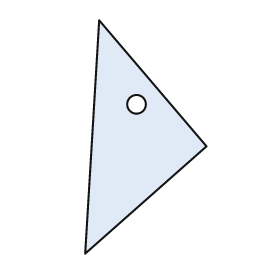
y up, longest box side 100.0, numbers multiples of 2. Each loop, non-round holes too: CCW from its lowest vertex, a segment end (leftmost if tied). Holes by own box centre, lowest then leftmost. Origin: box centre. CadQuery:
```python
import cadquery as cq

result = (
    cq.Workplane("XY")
    .moveTo(-26.0, -50.0)
    .lineTo(26.0, -4.0)
    .lineTo(-20.0, 50.0)
    .close()
    .moveTo(-4.0, 14.0)
    .circle(4.0)
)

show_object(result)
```